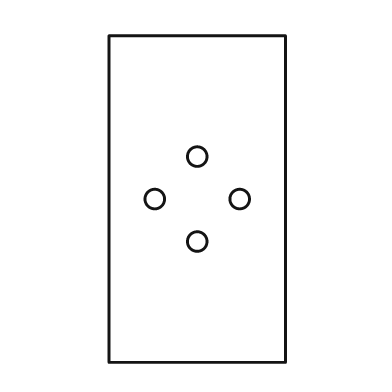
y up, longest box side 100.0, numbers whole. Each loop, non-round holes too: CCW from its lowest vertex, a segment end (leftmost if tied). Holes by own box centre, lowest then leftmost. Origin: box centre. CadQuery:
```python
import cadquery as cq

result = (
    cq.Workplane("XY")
    .moveTo(-27.0, -50.0)
    .lineTo(27.0, -50.0)
    .lineTo(27.0, 50.0)
    .lineTo(-27.0, 50.0)
    .close()
    .moveTo(0.0, -13.0)
    .circle(3.0)
    .moveTo(-13.0, 0.0)
    .circle(3.0)
    .moveTo(13.0, 0.0)
    .circle(3.0)
    .moveTo(0.0, 13.0)
    .circle(3.0)
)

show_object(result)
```